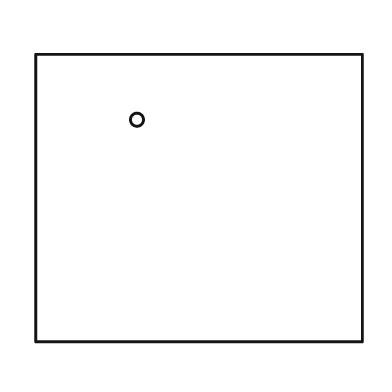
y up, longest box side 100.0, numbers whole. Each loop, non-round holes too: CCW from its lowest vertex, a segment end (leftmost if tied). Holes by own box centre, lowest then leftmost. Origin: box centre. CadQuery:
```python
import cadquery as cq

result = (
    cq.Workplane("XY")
    .moveTo(-50.0, -44.0)
    .lineTo(50.0, -44.0)
    .lineTo(50.0, 44.0)
    .lineTo(-50.0, 44.0)
    .close()
    .moveTo(-19.0, 24.0)
    .circle(2.0)
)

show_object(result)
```